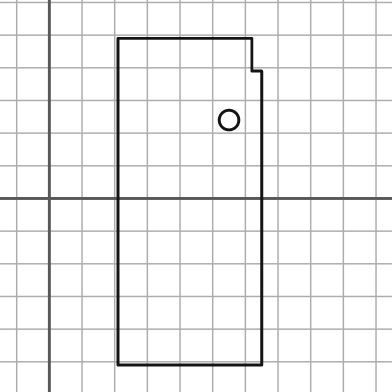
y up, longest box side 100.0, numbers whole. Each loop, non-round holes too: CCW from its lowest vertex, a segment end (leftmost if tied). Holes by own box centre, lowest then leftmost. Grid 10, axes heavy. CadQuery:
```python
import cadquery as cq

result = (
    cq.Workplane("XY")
    .moveTo(21.0, -51.0)
    .lineTo(65.0, -51.0)
    .lineTo(65.0, 39.0)
    .lineTo(62.0, 39.0)
    .lineTo(62.0, 49.0)
    .lineTo(21.0, 49.0)
    .close()
    .moveTo(55.0, 24.0)
    .circle(3.0)
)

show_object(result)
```